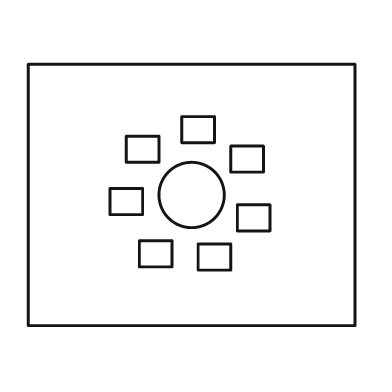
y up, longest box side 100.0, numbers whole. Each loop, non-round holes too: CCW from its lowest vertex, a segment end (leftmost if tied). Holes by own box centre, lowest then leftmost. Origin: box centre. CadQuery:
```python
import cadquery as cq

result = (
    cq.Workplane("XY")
    .moveTo(-50.0, -40.0)
    .lineTo(50.0, -40.0)
    .lineTo(50.0, 40.0)
    .lineTo(-50.0, 40.0)
    .close()
    .moveTo(2.0, -23.0)
    .lineTo(12.0, -23.0)
    .lineTo(12.0, -15.0)
    .lineTo(2.0, -15.0)
    .close()
    .moveTo(-16.0, -22.0)
    .lineTo(-6.0, -22.0)
    .lineTo(-6.0, -14.0)
    .lineTo(-16.0, -14.0)
    .close()
    .moveTo(14.0, -11.0)
    .lineTo(24.0, -11.0)
    .lineTo(24.0, -3.0)
    .lineTo(14.0, -3.0)
    .close()
    .moveTo(-25.0, -6.0)
    .lineTo(-15.0, -6.0)
    .lineTo(-15.0, 2.0)
    .lineTo(-25.0, 2.0)
    .close()
    .moveTo(0.0, 0.0)
    .circle(10.0)
    .moveTo(12.0, 7.0)
    .lineTo(22.0, 7.0)
    .lineTo(22.0, 15.0)
    .lineTo(12.0, 15.0)
    .close()
    .moveTo(-20.0, 10.0)
    .lineTo(-10.0, 10.0)
    .lineTo(-10.0, 18.0)
    .lineTo(-20.0, 18.0)
    .close()
    .moveTo(-3.0, 16.0)
    .lineTo(7.0, 16.0)
    .lineTo(7.0, 24.0)
    .lineTo(-3.0, 24.0)
    .close()
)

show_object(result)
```